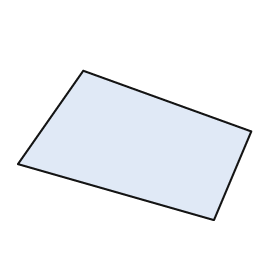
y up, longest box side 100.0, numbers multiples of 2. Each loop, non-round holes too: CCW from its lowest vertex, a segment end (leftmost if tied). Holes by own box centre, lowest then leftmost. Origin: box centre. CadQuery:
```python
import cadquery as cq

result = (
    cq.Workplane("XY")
    .moveTo(34.0, -32.0)
    .lineTo(50.0, 6.0)
    .lineTo(-22.0, 32.0)
    .lineTo(-50.0, -8.0)
    .close()
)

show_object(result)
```